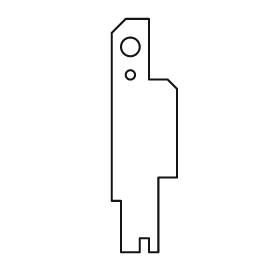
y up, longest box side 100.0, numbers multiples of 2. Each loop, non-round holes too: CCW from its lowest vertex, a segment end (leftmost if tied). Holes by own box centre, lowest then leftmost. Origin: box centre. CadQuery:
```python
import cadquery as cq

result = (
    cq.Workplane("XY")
    .moveTo(-10.0, -50.0)
    .lineTo(-2.0, -50.0)
    .lineTo(-2.0, -44.0)
    .lineTo(2.0, -44.0)
    .lineTo(2.0, -50.0)
    .lineTo(6.0, -50.0)
    .lineTo(6.0, -18.0)
    .lineTo(14.0, -18.0)
    .lineTo(14.0, 20.0)
    .lineTo(10.0, 24.0)
    .lineTo(2.0, 24.0)
    .lineTo(2.0, 50.0)
    .lineTo(-8.0, 50.0)
    .lineTo(-14.0, 44.0)
    .lineTo(-14.0, -28.0)
    .lineTo(-10.0, -28.0)
    .close()
    .moveTo(-6.0, 26.0)
    .circle(2.0)
    .moveTo(-6.0, 38.0)
    .circle(4.0)
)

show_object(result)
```